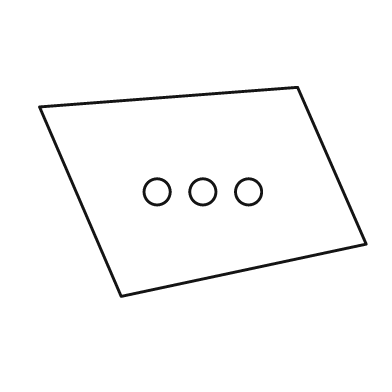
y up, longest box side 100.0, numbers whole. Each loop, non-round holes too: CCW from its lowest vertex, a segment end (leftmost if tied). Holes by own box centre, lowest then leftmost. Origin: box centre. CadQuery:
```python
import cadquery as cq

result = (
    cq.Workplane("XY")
    .moveTo(-25.0, -32.0)
    .lineTo(50.0, -16.0)
    .lineTo(29.0, 32.0)
    .lineTo(-50.0, 26.0)
    .close()
    .moveTo(-14.0, 0.0)
    .circle(4.0)
    .moveTo(0.0, 0.0)
    .circle(4.0)
    .moveTo(14.0, 0.0)
    .circle(4.0)
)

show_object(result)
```